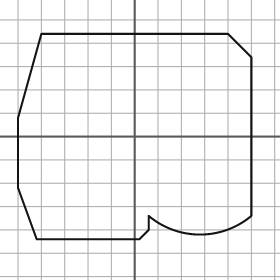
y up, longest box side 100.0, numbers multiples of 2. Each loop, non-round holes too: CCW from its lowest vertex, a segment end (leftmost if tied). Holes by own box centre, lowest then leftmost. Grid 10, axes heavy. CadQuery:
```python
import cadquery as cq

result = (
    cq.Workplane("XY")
    .moveTo(-42.0, -44.0)
    .lineTo(2.0, -44.0)
    .lineTo(6.0, -40.0)
    .lineTo(6.0, -34.0)
    .threePointArc((28.0, -42.0), (50.0, -34.0))
    .lineTo(50.0, 34.0)
    .lineTo(40.0, 44.0)
    .lineTo(-40.0, 44.0)
    .lineTo(-50.0, 8.0)
    .lineTo(-50.0, -22.0)
    .close()
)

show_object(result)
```